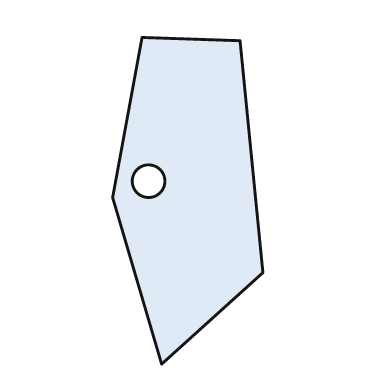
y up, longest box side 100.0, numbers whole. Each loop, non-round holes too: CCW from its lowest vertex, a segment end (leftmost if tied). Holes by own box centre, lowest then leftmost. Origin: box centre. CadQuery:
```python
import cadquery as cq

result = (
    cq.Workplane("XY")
    .moveTo(-8.0, -50.0)
    .lineTo(23.0, -22.0)
    .lineTo(16.0, 49.0)
    .lineTo(-14.0, 50.0)
    .lineTo(-23.0, 1.0)
    .close()
    .moveTo(-12.0, 6.0)
    .circle(5.0)
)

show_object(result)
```